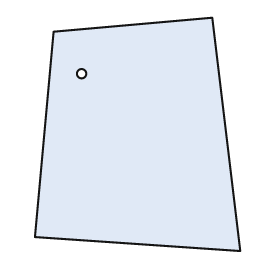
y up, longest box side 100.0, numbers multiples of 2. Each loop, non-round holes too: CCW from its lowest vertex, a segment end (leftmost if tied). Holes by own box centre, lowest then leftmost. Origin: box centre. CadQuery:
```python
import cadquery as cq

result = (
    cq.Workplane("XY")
    .moveTo(44.0, -50.0)
    .lineTo(32.0, 50.0)
    .lineTo(-36.0, 44.0)
    .lineTo(-44.0, -44.0)
    .close()
    .moveTo(-24.0, 26.0)
    .circle(2.0)
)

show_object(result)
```